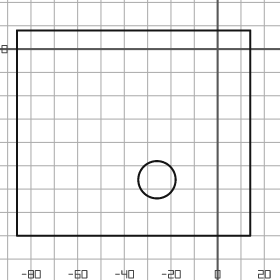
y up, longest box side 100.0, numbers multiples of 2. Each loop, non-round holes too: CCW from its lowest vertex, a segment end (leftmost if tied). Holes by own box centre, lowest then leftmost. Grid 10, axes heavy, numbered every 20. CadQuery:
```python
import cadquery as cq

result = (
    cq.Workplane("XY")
    .moveTo(-86.0, -80.0)
    .lineTo(14.0, -80.0)
    .lineTo(14.0, 8.0)
    .lineTo(-86.0, 8.0)
    .close()
    .moveTo(-26.0, -56.0)
    .circle(8.0)
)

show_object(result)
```